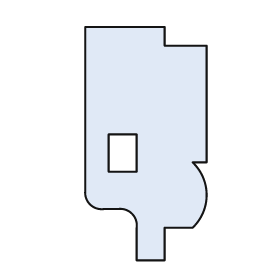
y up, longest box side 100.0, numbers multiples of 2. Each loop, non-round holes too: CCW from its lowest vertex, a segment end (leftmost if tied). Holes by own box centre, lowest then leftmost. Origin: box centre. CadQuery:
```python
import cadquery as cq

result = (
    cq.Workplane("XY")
    .moveTo(-4.0, -50.0)
    .lineTo(8.0, -50.0)
    .lineTo(8.0, -36.0)
    .lineTo(20.0, -36.0)
    .threePointArc((26.0, -22.0), (20.0, -8.0))
    .lineTo(26.0, -8.0)
    .lineTo(26.0, 42.0)
    .lineTo(8.0, 42.0)
    .lineTo(8.0, 50.0)
    .lineTo(-26.0, 50.0)
    .lineTo(-26.0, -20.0)
    .threePointArc((-24.0, -26.0), (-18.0, -28.0))
    .lineTo(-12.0, -28.0)
    .threePointArc((-6.0, -30.0), (-4.0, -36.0))
    .close()
    .moveTo(-16.0, -12.0)
    .lineTo(-4.0, -12.0)
    .lineTo(-4.0, 4.0)
    .lineTo(-16.0, 4.0)
    .close()
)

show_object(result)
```